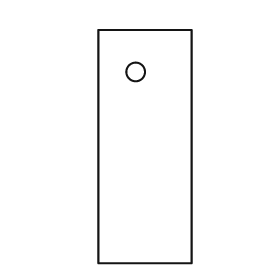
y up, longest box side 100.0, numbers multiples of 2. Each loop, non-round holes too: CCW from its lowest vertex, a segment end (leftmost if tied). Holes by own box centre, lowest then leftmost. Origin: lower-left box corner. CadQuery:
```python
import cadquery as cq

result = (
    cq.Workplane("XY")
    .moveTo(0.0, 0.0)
    .lineTo(40.0, 0.0)
    .lineTo(40.0, 100.0)
    .lineTo(0.0, 100.0)
    .close()
    .moveTo(16.0, 82.0)
    .circle(4.0)
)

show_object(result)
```